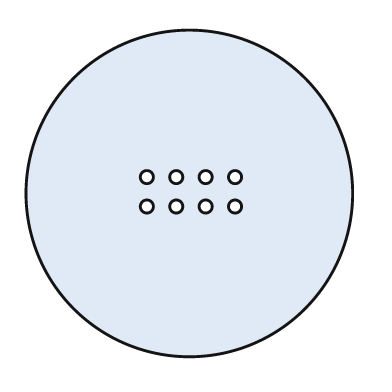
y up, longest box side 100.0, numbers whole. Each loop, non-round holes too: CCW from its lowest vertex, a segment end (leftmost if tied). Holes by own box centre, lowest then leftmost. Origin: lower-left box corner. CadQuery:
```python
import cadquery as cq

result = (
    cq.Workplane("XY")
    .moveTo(50.0, 50.0)
    .circle(50.0)
    .moveTo(37.0, 46.0)
    .circle(2.0)
    .moveTo(46.0, 46.0)
    .circle(2.0)
    .moveTo(55.0, 46.0)
    .circle(2.0)
    .moveTo(64.0, 46.0)
    .circle(2.0)
    .moveTo(37.0, 55.0)
    .circle(2.0)
    .moveTo(46.0, 55.0)
    .circle(2.0)
    .moveTo(55.0, 55.0)
    .circle(2.0)
    .moveTo(64.0, 55.0)
    .circle(2.0)
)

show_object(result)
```